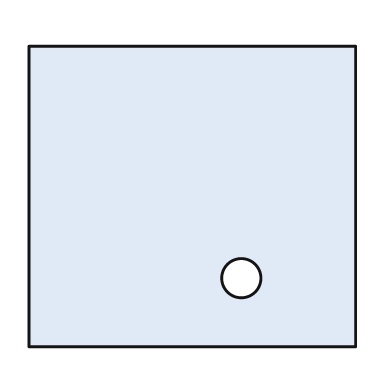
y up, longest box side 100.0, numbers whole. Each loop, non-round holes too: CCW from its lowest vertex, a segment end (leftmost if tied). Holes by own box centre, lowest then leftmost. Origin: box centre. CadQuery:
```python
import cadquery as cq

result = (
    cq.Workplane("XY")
    .moveTo(-50.0, -46.0)
    .lineTo(50.0, -46.0)
    .lineTo(50.0, 46.0)
    .lineTo(-50.0, 46.0)
    .close()
    .moveTo(15.0, -25.0)
    .circle(6.0)
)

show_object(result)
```